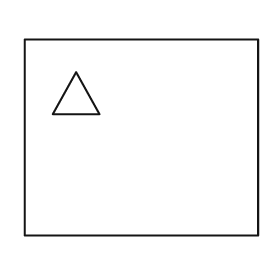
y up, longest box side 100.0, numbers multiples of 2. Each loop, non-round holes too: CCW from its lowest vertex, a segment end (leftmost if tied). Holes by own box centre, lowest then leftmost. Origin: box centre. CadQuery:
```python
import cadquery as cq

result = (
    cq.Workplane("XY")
    .moveTo(-50.0, -42.0)
    .lineTo(50.0, -42.0)
    .lineTo(50.0, 42.0)
    .lineTo(-50.0, 42.0)
    .close()
    .moveTo(-38.0, 10.0)
    .lineTo(-18.0, 10.0)
    .lineTo(-28.0, 28.0)
    .close()
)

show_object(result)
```